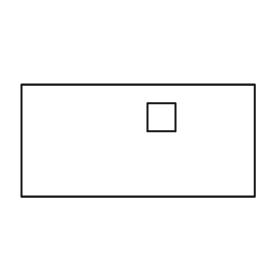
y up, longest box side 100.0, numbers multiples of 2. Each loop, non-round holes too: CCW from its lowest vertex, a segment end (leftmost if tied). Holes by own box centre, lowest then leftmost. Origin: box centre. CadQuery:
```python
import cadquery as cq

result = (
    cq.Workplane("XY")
    .moveTo(-50.0, -24.0)
    .lineTo(50.0, -24.0)
    .lineTo(50.0, 24.0)
    .lineTo(-50.0, 24.0)
    .close()
    .moveTo(4.0, 4.0)
    .lineTo(16.0, 4.0)
    .lineTo(16.0, 16.0)
    .lineTo(4.0, 16.0)
    .close()
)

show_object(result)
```